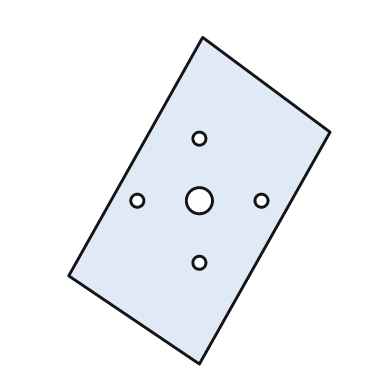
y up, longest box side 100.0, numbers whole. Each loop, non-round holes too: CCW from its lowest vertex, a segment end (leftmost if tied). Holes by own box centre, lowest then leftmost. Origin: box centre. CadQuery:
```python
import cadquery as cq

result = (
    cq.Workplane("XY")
    .moveTo(0.0, -50.0)
    .lineTo(40.0, 21.0)
    .lineTo(1.0, 50.0)
    .lineTo(-40.0, -23.0)
    .close()
    .moveTo(0.0, -19.0)
    .circle(2.0)
    .moveTo(-19.0, 0.0)
    .circle(2.0)
    .moveTo(0.0, 0.0)
    .circle(4.0)
    .moveTo(19.0, 0.0)
    .circle(2.0)
    .moveTo(0.0, 19.0)
    .circle(2.0)
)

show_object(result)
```